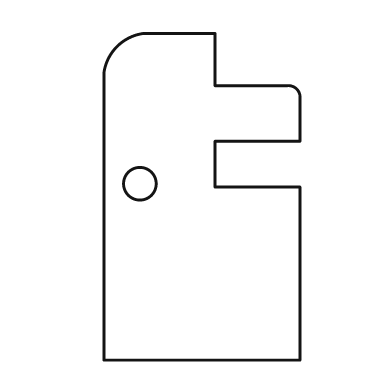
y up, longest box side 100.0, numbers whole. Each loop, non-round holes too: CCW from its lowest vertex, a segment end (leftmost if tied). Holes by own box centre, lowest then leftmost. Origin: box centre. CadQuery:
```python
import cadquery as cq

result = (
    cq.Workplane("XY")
    .moveTo(-30.0, -50.0)
    .lineTo(30.0, -50.0)
    .lineTo(30.0, 3.0)
    .lineTo(4.0, 3.0)
    .lineTo(4.0, 17.0)
    .lineTo(30.0, 17.0)
    .lineTo(30.0, 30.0)
    .threePointArc((29.0, 33.0), (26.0, 34.0))
    .lineTo(4.0, 34.0)
    .lineTo(4.0, 50.0)
    .lineTo(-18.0, 50.0)
    .threePointArc((-26.0, 46.0), (-30.0, 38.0))
    .close()
    .moveTo(-19.0, 4.0)
    .circle(5.0)
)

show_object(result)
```